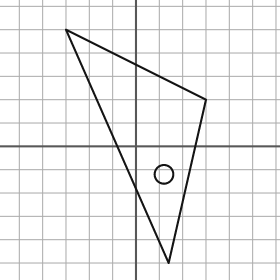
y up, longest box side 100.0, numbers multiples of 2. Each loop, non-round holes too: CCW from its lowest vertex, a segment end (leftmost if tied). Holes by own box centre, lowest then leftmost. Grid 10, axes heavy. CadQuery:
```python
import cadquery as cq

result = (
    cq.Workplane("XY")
    .moveTo(14.0, -50.0)
    .lineTo(30.0, 20.0)
    .lineTo(-30.0, 50.0)
    .close()
    .moveTo(12.0, -12.0)
    .circle(4.0)
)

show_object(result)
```